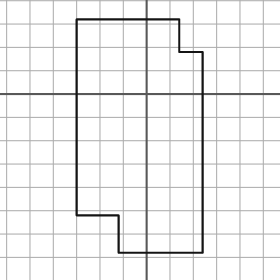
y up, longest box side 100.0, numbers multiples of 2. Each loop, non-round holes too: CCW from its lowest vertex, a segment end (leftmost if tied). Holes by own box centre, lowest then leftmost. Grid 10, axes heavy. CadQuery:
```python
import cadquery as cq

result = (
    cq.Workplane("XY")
    .moveTo(-12.0, -68.0)
    .lineTo(24.0, -68.0)
    .lineTo(24.0, 18.0)
    .lineTo(14.0, 18.0)
    .lineTo(14.0, 32.0)
    .lineTo(-30.0, 32.0)
    .lineTo(-30.0, -52.0)
    .lineTo(-12.0, -52.0)
    .close()
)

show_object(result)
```